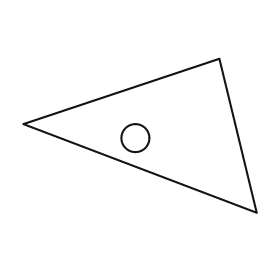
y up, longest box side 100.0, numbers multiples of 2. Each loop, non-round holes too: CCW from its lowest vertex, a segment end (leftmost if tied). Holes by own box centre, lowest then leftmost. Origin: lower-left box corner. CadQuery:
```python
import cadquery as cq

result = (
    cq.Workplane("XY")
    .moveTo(100.0, 0.0)
    .lineTo(84.0, 66.0)
    .lineTo(0.0, 38.0)
    .close()
    .moveTo(48.0, 32.0)
    .circle(6.0)
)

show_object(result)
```